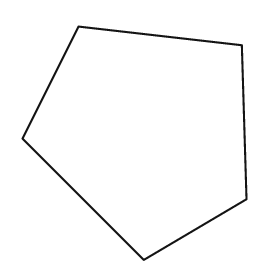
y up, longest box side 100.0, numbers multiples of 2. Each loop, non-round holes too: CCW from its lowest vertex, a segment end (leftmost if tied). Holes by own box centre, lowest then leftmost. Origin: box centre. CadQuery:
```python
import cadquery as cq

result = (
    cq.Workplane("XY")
    .moveTo(4.0, -50.0)
    .lineTo(48.0, -24.0)
    .lineTo(46.0, 42.0)
    .lineTo(-24.0, 50.0)
    .lineTo(-48.0, 2.0)
    .close()
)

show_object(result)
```